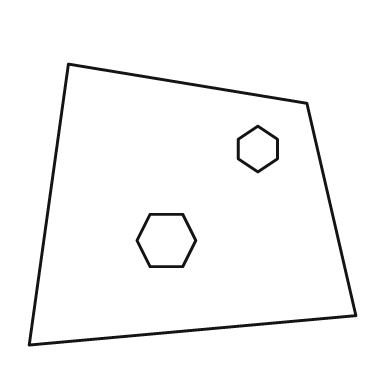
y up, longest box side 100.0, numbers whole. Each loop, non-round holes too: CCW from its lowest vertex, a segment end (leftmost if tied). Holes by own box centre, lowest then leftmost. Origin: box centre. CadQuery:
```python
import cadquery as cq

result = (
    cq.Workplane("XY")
    .moveTo(-50.0, -43.0)
    .lineTo(50.0, -34.0)
    .lineTo(35.0, 31.0)
    .lineTo(-38.0, 43.0)
    .close()
    .moveTo(-13.0, -19.0)
    .lineTo(-3.0, -19.0)
    .lineTo(1.0, -11.0)
    .lineTo(-3.0, -3.0)
    .lineTo(-13.0, -3.0)
    .lineTo(-17.0, -11.0)
    .close()
    .moveTo(20.0, 10.0)
    .lineTo(26.0, 14.0)
    .lineTo(26.0, 20.0)
    .lineTo(20.0, 24.0)
    .lineTo(14.0, 20.0)
    .lineTo(14.0, 14.0)
    .close()
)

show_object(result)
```